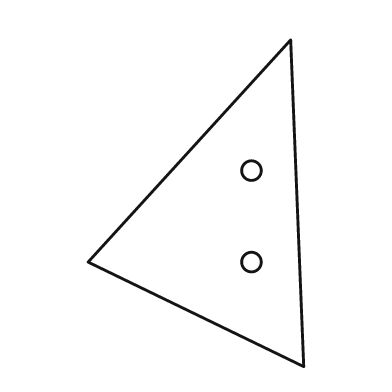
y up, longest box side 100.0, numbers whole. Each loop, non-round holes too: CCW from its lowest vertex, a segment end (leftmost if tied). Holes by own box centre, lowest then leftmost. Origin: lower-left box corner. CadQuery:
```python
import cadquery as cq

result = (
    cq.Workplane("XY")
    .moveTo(66.0, 0.0)
    .lineTo(62.0, 100.0)
    .lineTo(0.0, 32.0)
    .close()
    .moveTo(50.0, 32.0)
    .circle(3.0)
    .moveTo(50.0, 60.0)
    .circle(3.0)
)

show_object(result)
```